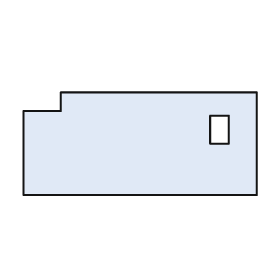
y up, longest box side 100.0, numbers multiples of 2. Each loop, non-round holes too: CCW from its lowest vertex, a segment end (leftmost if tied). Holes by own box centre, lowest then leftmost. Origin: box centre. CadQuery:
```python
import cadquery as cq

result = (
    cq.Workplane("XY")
    .moveTo(-50.0, -22.0)
    .lineTo(50.0, -22.0)
    .lineTo(50.0, 22.0)
    .lineTo(-34.0, 22.0)
    .lineTo(-34.0, 14.0)
    .lineTo(-50.0, 14.0)
    .close()
    .moveTo(30.0, 0.0)
    .lineTo(38.0, 0.0)
    .lineTo(38.0, 12.0)
    .lineTo(30.0, 12.0)
    .close()
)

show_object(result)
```